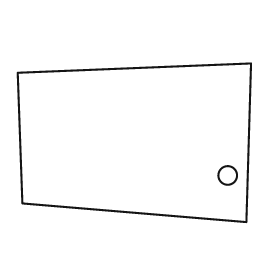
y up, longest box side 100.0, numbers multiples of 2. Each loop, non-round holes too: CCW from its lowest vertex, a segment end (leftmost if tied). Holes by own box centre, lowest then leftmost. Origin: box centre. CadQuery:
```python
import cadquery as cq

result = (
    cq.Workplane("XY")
    .moveTo(48.0, -34.0)
    .lineTo(50.0, 34.0)
    .lineTo(-50.0, 30.0)
    .lineTo(-48.0, -26.0)
    .close()
    .moveTo(40.0, -14.0)
    .circle(4.0)
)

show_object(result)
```